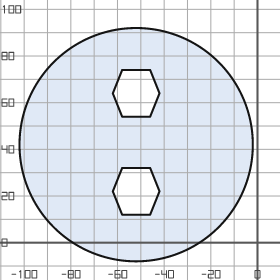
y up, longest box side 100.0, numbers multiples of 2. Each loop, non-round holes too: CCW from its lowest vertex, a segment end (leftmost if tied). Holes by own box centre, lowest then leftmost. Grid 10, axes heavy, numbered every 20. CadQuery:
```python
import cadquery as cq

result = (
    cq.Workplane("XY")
    .moveTo(-52.0, 42.0)
    .circle(50.0)
    .moveTo(-58.0, 12.0)
    .lineTo(-46.0, 12.0)
    .lineTo(-42.0, 22.0)
    .lineTo(-46.0, 32.0)
    .lineTo(-58.0, 32.0)
    .lineTo(-62.0, 22.0)
    .close()
    .moveTo(-58.0, 54.0)
    .lineTo(-46.0, 54.0)
    .lineTo(-42.0, 64.0)
    .lineTo(-46.0, 74.0)
    .lineTo(-58.0, 74.0)
    .lineTo(-62.0, 64.0)
    .close()
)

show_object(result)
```